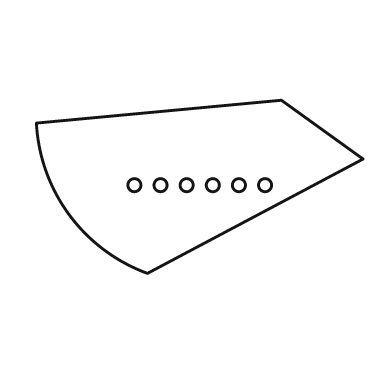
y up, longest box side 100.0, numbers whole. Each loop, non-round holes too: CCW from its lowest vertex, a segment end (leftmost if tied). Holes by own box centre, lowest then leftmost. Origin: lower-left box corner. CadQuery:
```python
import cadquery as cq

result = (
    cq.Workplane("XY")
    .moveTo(34.0, 0.0)
    .lineTo(100.0, 35.0)
    .lineTo(75.0, 53.0)
    .lineTo(0.0, 46.0)
    .threePointArc((10.0, 18.0), (34.0, 0.0))
    .close()
    .moveTo(30.0, 27.0)
    .circle(2.0)
    .moveTo(38.0, 27.0)
    .circle(2.0)
    .moveTo(46.0, 27.0)
    .circle(2.0)
    .moveTo(54.0, 27.0)
    .circle(2.0)
    .moveTo(62.0, 27.0)
    .circle(2.0)
    .moveTo(70.0, 27.0)
    .circle(2.0)
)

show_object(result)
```